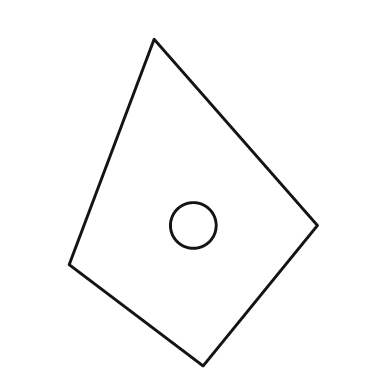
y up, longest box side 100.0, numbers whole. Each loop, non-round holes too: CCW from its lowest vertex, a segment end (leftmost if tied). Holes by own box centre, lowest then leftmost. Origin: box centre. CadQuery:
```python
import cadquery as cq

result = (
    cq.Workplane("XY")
    .moveTo(3.0, -50.0)
    .lineTo(38.0, -7.0)
    .lineTo(-12.0, 50.0)
    .lineTo(-38.0, -19.0)
    .close()
    .moveTo(0.0, -7.0)
    .circle(7.0)
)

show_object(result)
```